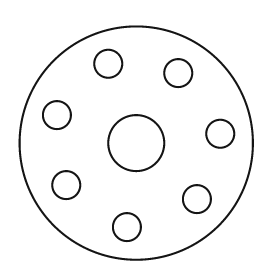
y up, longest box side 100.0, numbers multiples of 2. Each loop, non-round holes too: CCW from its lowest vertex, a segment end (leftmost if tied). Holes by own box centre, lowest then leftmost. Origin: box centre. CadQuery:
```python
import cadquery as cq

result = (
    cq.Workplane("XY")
    .moveTo(0.0, 0.0)
    .circle(50.0)
    .moveTo(-4.0, -36.0)
    .circle(6.0)
    .moveTo(26.0, -24.0)
    .circle(6.0)
    .moveTo(-30.0, -18.0)
    .circle(6.0)
    .moveTo(0.0, 0.0)
    .circle(12.0)
    .moveTo(36.0, 4.0)
    .circle(6.0)
    .moveTo(-34.0, 12.0)
    .circle(6.0)
    .moveTo(18.0, 30.0)
    .circle(6.0)
    .moveTo(-12.0, 34.0)
    .circle(6.0)
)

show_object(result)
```